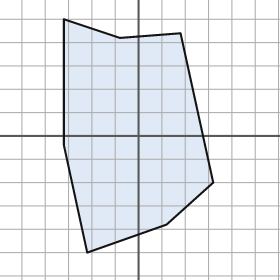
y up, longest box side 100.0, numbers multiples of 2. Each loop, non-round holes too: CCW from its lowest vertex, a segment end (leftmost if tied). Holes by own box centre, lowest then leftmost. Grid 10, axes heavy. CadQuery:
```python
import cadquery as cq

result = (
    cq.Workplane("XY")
    .moveTo(-22.0, -50.0)
    .lineTo(12.0, -38.0)
    .lineTo(32.0, -20.0)
    .lineTo(18.0, 44.0)
    .lineTo(-8.0, 42.0)
    .lineTo(-32.0, 50.0)
    .lineTo(-32.0, -4.0)
    .close()
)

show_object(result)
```